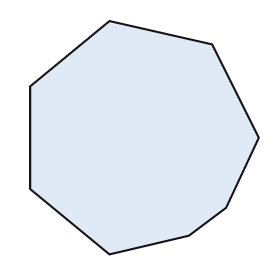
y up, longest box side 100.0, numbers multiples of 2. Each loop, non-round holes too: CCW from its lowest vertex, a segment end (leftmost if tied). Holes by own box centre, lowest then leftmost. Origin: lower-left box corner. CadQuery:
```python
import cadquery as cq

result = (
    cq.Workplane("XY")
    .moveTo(34.0, 0.0)
    .lineTo(68.0, 8.0)
    .lineTo(84.0, 20.0)
    .lineTo(98.0, 50.0)
    .lineTo(78.0, 90.0)
    .lineTo(34.0, 100.0)
    .lineTo(0.0, 72.0)
    .lineTo(0.0, 28.0)
    .close()
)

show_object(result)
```